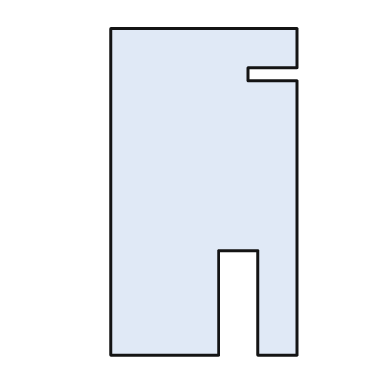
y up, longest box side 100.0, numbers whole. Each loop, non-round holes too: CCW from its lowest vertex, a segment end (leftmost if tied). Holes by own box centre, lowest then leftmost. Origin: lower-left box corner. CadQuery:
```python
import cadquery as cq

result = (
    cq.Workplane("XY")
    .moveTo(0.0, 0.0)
    .lineTo(33.0, 0.0)
    .lineTo(33.0, 32.0)
    .lineTo(45.0, 32.0)
    .lineTo(45.0, 0.0)
    .lineTo(57.0, 0.0)
    .lineTo(57.0, 84.0)
    .lineTo(42.0, 84.0)
    .lineTo(42.0, 88.0)
    .lineTo(57.0, 88.0)
    .lineTo(57.0, 100.0)
    .lineTo(0.0, 100.0)
    .close()
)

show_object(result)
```